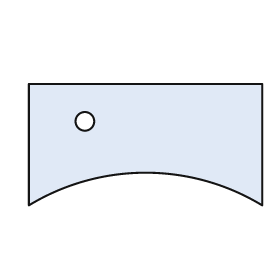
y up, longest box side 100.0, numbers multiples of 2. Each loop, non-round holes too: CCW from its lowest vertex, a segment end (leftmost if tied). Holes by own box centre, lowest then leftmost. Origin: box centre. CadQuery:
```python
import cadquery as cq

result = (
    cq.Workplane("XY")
    .moveTo(-50.0, -26.0)
    .threePointArc((0.0, -12.0), (50.0, -26.0))
    .lineTo(50.0, 26.0)
    .lineTo(-50.0, 26.0)
    .close()
    .moveTo(-26.0, 10.0)
    .circle(4.0)
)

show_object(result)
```